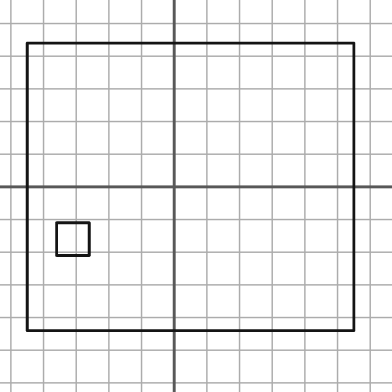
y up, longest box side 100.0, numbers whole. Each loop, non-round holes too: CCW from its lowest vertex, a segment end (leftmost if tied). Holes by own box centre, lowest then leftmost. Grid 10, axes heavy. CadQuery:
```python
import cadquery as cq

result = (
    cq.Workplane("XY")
    .moveTo(-45.0, -44.0)
    .lineTo(55.0, -44.0)
    .lineTo(55.0, 44.0)
    .lineTo(-45.0, 44.0)
    .close()
    .moveTo(-36.0, -21.0)
    .lineTo(-26.0, -21.0)
    .lineTo(-26.0, -11.0)
    .lineTo(-36.0, -11.0)
    .close()
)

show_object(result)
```